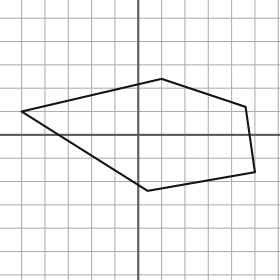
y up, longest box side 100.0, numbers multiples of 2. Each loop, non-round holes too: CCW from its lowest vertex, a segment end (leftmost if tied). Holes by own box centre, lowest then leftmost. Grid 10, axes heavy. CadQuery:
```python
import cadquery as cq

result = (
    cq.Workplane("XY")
    .moveTo(4.0, -24.0)
    .lineTo(50.0, -16.0)
    .lineTo(46.0, 12.0)
    .lineTo(10.0, 24.0)
    .lineTo(-50.0, 10.0)
    .close()
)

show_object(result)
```